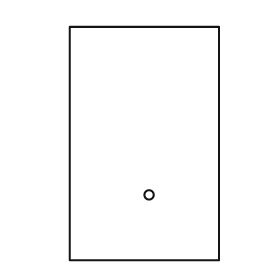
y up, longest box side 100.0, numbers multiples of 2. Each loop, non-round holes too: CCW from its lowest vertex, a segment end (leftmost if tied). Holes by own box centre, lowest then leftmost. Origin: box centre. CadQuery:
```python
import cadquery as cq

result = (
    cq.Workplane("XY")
    .moveTo(-32.0, -50.0)
    .lineTo(32.0, -50.0)
    .lineTo(32.0, 50.0)
    .lineTo(-32.0, 50.0)
    .close()
    .moveTo(2.0, -22.0)
    .circle(2.0)
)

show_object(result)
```